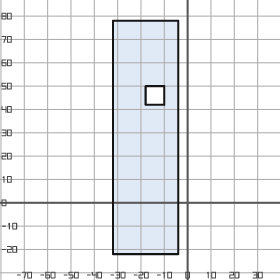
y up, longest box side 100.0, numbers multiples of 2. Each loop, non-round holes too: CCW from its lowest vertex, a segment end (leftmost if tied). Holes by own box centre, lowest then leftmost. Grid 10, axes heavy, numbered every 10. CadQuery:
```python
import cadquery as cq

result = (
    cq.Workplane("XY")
    .moveTo(-32.0, -22.0)
    .lineTo(-4.0, -22.0)
    .lineTo(-4.0, 78.0)
    .lineTo(-32.0, 78.0)
    .close()
    .moveTo(-18.0, 42.0)
    .lineTo(-10.0, 42.0)
    .lineTo(-10.0, 50.0)
    .lineTo(-18.0, 50.0)
    .close()
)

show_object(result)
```